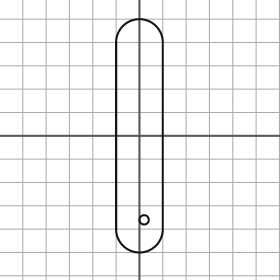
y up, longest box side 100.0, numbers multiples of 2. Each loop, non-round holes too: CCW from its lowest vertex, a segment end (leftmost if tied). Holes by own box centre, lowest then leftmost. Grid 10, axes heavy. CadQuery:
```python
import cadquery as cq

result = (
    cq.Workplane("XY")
    .moveTo(-10.0, -40.0)
    .threePointArc((0.0, -50.0), (10.0, -40.0))
    .lineTo(10.0, 40.0)
    .threePointArc((0.0, 50.0), (-10.0, 40.0))
    .close()
    .moveTo(2.0, -36.0)
    .circle(2.0)
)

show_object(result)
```